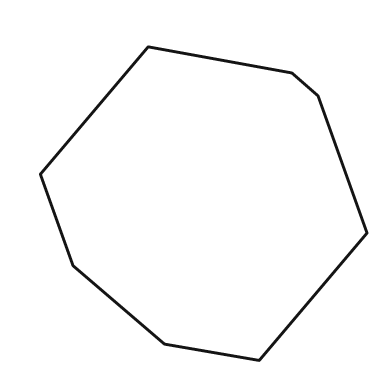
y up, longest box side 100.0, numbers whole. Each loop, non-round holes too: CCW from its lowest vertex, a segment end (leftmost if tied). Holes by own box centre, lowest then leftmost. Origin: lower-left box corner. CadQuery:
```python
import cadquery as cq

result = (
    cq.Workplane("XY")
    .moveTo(67.0, 0.0)
    .lineTo(100.0, 39.0)
    .lineTo(85.0, 81.0)
    .lineTo(77.0, 88.0)
    .lineTo(33.0, 96.0)
    .lineTo(0.0, 57.0)
    .lineTo(10.0, 29.0)
    .lineTo(38.0, 5.0)
    .close()
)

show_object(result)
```